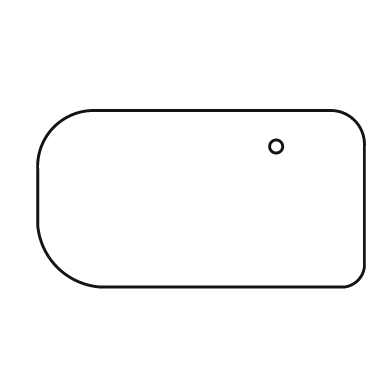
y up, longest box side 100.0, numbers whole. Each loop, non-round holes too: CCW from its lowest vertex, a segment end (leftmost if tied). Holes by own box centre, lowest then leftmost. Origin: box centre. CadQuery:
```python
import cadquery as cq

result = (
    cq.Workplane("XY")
    .moveTo(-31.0, -27.0)
    .lineTo(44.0, -27.0)
    .threePointArc((48.0, -25.0), (50.0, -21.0))
    .lineTo(50.0, 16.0)
    .threePointArc((47.0, 24.0), (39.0, 27.0))
    .lineTo(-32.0, 27.0)
    .threePointArc((-45.0, 22.0), (-50.0, 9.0))
    .lineTo(-50.0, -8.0)
    .threePointArc((-44.0, -21.0), (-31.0, -27.0))
    .close()
    .moveTo(23.0, 16.0)
    .circle(2.0)
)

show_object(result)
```